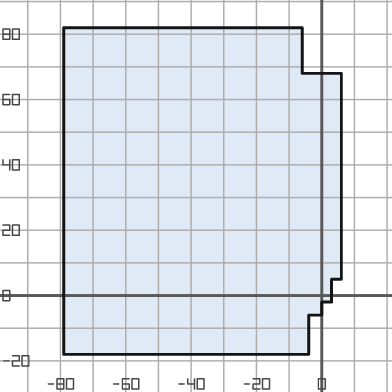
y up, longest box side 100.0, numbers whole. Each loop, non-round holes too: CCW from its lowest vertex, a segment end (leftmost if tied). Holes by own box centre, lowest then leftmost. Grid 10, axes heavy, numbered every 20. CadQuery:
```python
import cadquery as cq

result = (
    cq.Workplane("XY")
    .moveTo(-79.0, -18.0)
    .lineTo(-4.0, -18.0)
    .lineTo(-4.0, -6.0)
    .lineTo(0.0, -6.0)
    .lineTo(0.0, -2.0)
    .lineTo(3.0, -2.0)
    .lineTo(3.0, 5.0)
    .lineTo(6.0, 5.0)
    .lineTo(6.0, 68.0)
    .lineTo(-6.0, 68.0)
    .lineTo(-6.0, 82.0)
    .lineTo(-79.0, 82.0)
    .close()
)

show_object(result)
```